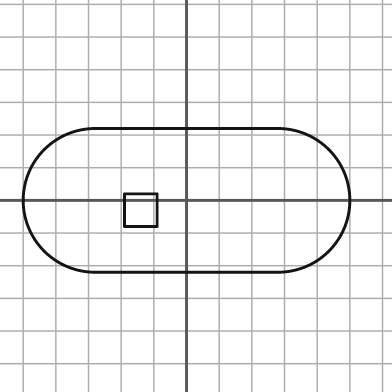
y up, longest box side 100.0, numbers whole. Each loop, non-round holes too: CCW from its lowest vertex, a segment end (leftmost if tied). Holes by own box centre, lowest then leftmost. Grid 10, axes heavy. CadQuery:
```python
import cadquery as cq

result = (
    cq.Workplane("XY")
    .moveTo(-28.0, -22.0)
    .lineTo(28.0, -22.0)
    .threePointArc((50.0, 0.0), (28.0, 22.0))
    .lineTo(-28.0, 22.0)
    .threePointArc((-50.0, 0.0), (-28.0, -22.0))
    .close()
    .moveTo(-19.0, -8.0)
    .lineTo(-9.0, -8.0)
    .lineTo(-9.0, 2.0)
    .lineTo(-19.0, 2.0)
    .close()
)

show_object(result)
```